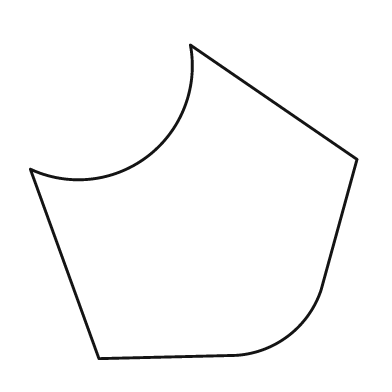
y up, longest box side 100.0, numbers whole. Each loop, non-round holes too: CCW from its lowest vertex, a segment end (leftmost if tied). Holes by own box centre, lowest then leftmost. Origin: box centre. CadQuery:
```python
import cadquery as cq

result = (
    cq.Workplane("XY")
    .moveTo(-29.0, -48.0)
    .lineTo(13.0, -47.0)
    .threePointArc((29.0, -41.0), (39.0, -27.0))
    .lineTo(50.0, 13.0)
    .lineTo(-1.0, 48.0)
    .threePointArc((-14.0, 14.0), (-50.0, 10.0))
    .close()
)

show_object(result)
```